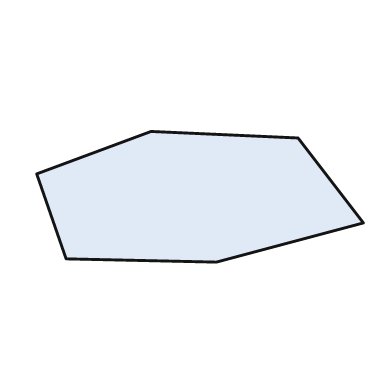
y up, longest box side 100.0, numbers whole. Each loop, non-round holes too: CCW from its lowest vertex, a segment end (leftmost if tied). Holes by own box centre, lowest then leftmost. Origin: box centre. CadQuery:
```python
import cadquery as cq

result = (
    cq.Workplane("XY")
    .moveTo(5.0, -20.0)
    .lineTo(50.0, -8.0)
    .lineTo(30.0, 18.0)
    .lineTo(-15.0, 20.0)
    .lineTo(-50.0, 7.0)
    .lineTo(-41.0, -19.0)
    .close()
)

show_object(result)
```